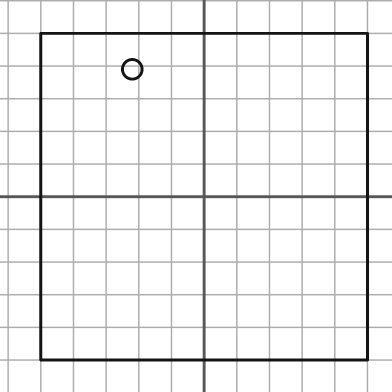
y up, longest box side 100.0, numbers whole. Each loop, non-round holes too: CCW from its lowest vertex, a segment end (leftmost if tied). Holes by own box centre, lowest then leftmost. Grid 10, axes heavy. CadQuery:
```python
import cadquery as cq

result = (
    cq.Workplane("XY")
    .moveTo(-50.0, -50.0)
    .lineTo(50.0, -50.0)
    .lineTo(50.0, 50.0)
    .lineTo(-50.0, 50.0)
    .close()
    .moveTo(-22.0, 39.0)
    .circle(3.0)
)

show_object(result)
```